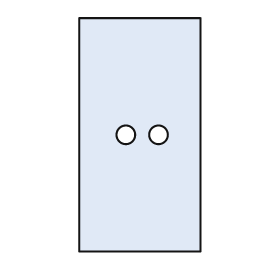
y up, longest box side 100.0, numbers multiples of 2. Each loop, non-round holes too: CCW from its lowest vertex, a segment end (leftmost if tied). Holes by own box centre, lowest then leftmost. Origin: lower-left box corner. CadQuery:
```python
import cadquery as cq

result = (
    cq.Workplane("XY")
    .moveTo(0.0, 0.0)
    .lineTo(52.0, 0.0)
    .lineTo(52.0, 100.0)
    .lineTo(0.0, 100.0)
    .close()
    .moveTo(20.0, 50.0)
    .circle(4.0)
    .moveTo(34.0, 50.0)
    .circle(4.0)
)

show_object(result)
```